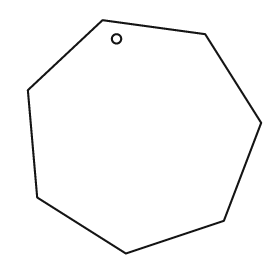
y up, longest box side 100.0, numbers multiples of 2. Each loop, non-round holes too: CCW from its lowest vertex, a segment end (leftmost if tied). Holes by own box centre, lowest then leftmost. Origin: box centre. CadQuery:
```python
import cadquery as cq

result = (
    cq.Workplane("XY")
    .moveTo(-8.0, -50.0)
    .lineTo(34.0, -36.0)
    .lineTo(50.0, 6.0)
    .lineTo(26.0, 44.0)
    .lineTo(-18.0, 50.0)
    .lineTo(-50.0, 20.0)
    .lineTo(-46.0, -26.0)
    .close()
    .moveTo(-12.0, 42.0)
    .circle(2.0)
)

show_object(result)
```